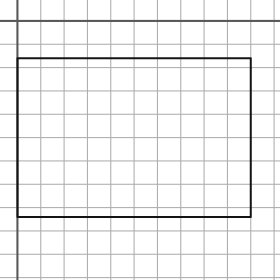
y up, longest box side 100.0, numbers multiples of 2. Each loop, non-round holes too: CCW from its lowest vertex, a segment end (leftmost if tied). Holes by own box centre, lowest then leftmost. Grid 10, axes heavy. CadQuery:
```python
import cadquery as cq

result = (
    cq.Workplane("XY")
    .moveTo(0.0, -84.0)
    .lineTo(100.0, -84.0)
    .lineTo(100.0, -16.0)
    .lineTo(0.0, -16.0)
    .close()
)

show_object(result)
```